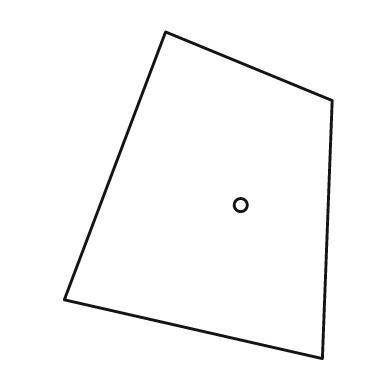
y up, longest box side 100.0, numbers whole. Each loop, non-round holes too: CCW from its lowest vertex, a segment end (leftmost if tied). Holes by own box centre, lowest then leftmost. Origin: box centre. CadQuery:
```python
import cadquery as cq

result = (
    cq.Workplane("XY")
    .moveTo(38.0, -50.0)
    .lineTo(41.0, 29.0)
    .lineTo(-10.0, 50.0)
    .lineTo(-41.0, -32.0)
    .close()
    .moveTo(13.0, -3.0)
    .circle(2.0)
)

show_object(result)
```